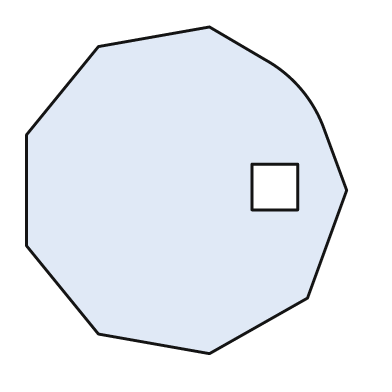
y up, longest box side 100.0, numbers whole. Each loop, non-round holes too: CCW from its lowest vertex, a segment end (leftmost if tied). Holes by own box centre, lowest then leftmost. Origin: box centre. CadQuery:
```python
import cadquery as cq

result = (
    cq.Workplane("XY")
    .moveTo(7.0, -50.0)
    .lineTo(37.0, -33.0)
    .lineTo(49.0, 0.0)
    .lineTo(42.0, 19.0)
    .threePointArc((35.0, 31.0), (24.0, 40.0))
    .lineTo(7.0, 50.0)
    .lineTo(-27.0, 44.0)
    .lineTo(-49.0, 17.0)
    .lineTo(-49.0, -17.0)
    .lineTo(-27.0, -44.0)
    .close()
    .moveTo(20.0, -6.0)
    .lineTo(34.0, -6.0)
    .lineTo(34.0, 8.0)
    .lineTo(20.0, 8.0)
    .close()
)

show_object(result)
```